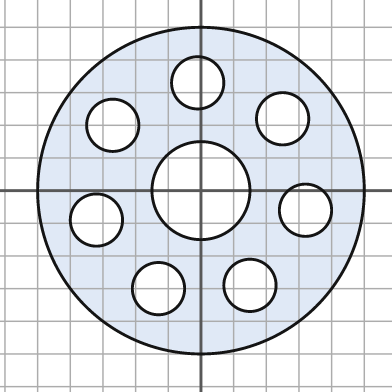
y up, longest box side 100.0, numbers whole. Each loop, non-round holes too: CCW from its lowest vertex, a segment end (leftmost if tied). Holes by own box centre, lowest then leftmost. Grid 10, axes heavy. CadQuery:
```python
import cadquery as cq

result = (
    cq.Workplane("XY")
    .moveTo(0.0, 0.0)
    .circle(50.0)
    .moveTo(-13.0, -30.0)
    .circle(8.0)
    .moveTo(15.0, -29.0)
    .circle(8.0)
    .moveTo(-32.0, -9.0)
    .circle(8.0)
    .moveTo(32.0, -6.0)
    .circle(8.0)
    .moveTo(0.0, 0.0)
    .circle(15.0)
    .moveTo(-27.0, 20.0)
    .circle(8.0)
    .moveTo(25.0, 22.0)
    .circle(8.0)
    .moveTo(-1.0, 33.0)
    .circle(8.0)
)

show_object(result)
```